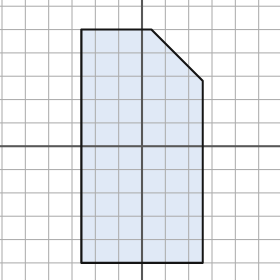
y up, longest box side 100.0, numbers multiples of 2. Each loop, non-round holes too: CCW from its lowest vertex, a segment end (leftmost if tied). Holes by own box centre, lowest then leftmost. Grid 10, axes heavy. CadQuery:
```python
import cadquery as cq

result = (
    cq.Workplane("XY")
    .moveTo(-26.0, -50.0)
    .lineTo(26.0, -50.0)
    .lineTo(26.0, 28.0)
    .lineTo(4.0, 50.0)
    .lineTo(-26.0, 50.0)
    .close()
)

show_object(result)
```